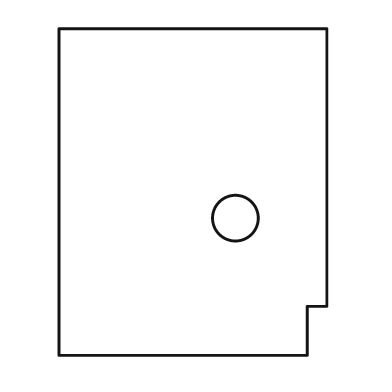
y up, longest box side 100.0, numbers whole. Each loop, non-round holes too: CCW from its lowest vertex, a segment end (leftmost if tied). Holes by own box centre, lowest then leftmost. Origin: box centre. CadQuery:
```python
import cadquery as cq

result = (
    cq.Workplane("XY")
    .moveTo(-41.0, -50.0)
    .lineTo(35.0, -50.0)
    .lineTo(35.0, -35.0)
    .lineTo(41.0, -35.0)
    .lineTo(41.0, 50.0)
    .lineTo(-41.0, 50.0)
    .close()
    .moveTo(13.0, -8.0)
    .circle(7.0)
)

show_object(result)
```